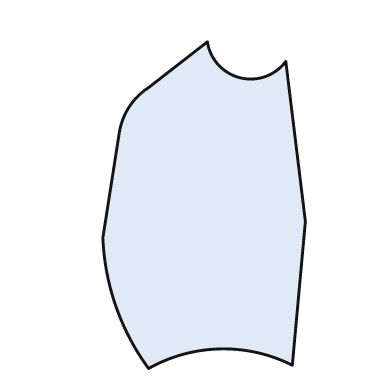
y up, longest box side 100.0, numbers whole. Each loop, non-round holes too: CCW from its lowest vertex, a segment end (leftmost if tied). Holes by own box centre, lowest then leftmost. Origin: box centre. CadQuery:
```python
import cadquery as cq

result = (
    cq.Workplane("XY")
    .moveTo(-17.0, -50.0)
    .threePointArc((5.0, -44.0), (27.0, -49.0))
    .lineTo(31.0, -5.0)
    .lineTo(25.0, 44.0)
    .threePointArc((11.0, 39.0), (1.0, 50.0))
    .lineTo(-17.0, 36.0)
    .threePointArc((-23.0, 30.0), (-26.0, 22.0))
    .lineTo(-31.0, -10.0)
    .threePointArc((-27.0, -31.0), (-17.0, -50.0))
    .close()
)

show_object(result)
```